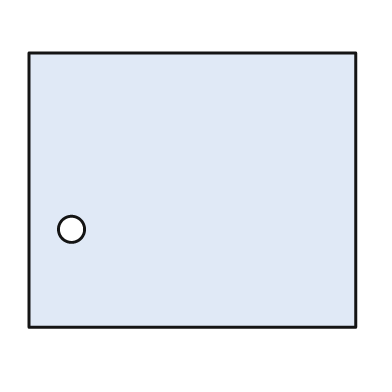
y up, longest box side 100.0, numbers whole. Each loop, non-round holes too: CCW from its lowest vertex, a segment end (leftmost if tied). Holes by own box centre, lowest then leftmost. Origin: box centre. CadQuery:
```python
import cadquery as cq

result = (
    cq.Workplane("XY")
    .moveTo(-50.0, -42.0)
    .lineTo(50.0, -42.0)
    .lineTo(50.0, 42.0)
    .lineTo(-50.0, 42.0)
    .close()
    .moveTo(-37.0, -12.0)
    .circle(4.0)
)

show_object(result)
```